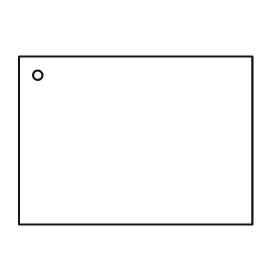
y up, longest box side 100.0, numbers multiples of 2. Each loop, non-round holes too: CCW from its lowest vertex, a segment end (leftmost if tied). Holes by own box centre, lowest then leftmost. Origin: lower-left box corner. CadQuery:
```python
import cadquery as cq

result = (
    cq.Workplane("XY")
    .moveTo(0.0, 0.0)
    .lineTo(100.0, 0.0)
    .lineTo(100.0, 72.0)
    .lineTo(0.0, 72.0)
    .close()
    .moveTo(8.0, 64.0)
    .circle(2.0)
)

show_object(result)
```